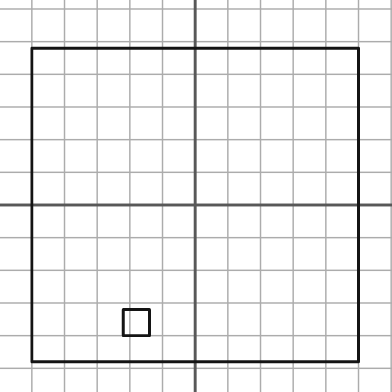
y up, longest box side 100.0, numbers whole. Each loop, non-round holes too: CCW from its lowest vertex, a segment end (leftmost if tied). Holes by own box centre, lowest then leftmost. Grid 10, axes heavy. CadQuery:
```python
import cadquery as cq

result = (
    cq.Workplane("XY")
    .moveTo(-50.0, -48.0)
    .lineTo(50.0, -48.0)
    .lineTo(50.0, 48.0)
    .lineTo(-50.0, 48.0)
    .close()
    .moveTo(-22.0, -40.0)
    .lineTo(-14.0, -40.0)
    .lineTo(-14.0, -32.0)
    .lineTo(-22.0, -32.0)
    .close()
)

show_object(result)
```